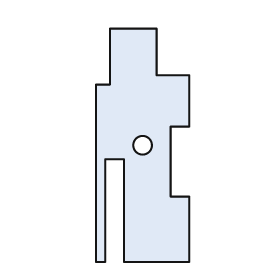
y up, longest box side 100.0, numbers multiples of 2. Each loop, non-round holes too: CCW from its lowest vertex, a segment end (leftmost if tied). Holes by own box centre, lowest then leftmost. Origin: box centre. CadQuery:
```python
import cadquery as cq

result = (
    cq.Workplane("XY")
    .moveTo(-20.0, -50.0)
    .lineTo(-16.0, -50.0)
    .lineTo(-16.0, -6.0)
    .lineTo(-8.0, -6.0)
    .lineTo(-8.0, -50.0)
    .lineTo(20.0, -50.0)
    .lineTo(20.0, -22.0)
    .lineTo(12.0, -22.0)
    .lineTo(12.0, 8.0)
    .lineTo(20.0, 8.0)
    .lineTo(20.0, 30.0)
    .lineTo(6.0, 30.0)
    .lineTo(6.0, 50.0)
    .lineTo(-14.0, 50.0)
    .lineTo(-14.0, 26.0)
    .lineTo(-20.0, 26.0)
    .close()
    .moveTo(0.0, 0.0)
    .circle(4.0)
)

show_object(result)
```